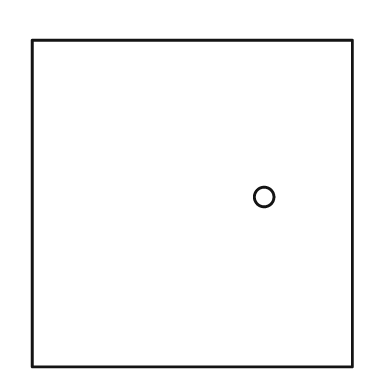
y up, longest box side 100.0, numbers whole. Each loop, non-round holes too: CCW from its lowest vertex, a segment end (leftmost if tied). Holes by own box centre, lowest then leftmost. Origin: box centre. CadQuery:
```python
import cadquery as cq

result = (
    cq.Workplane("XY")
    .moveTo(-49.0, -50.0)
    .lineTo(49.0, -50.0)
    .lineTo(49.0, 50.0)
    .lineTo(-49.0, 50.0)
    .close()
    .moveTo(22.0, 2.0)
    .circle(3.0)
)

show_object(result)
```